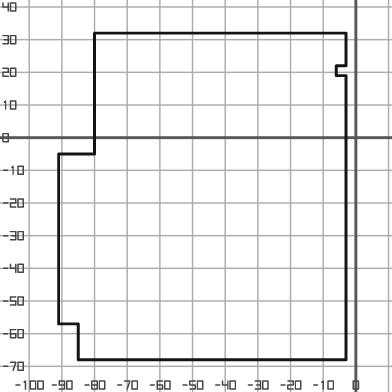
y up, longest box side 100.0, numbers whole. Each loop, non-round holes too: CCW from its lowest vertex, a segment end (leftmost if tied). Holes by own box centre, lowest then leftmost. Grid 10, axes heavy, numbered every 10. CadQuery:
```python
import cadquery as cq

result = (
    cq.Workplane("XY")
    .moveTo(-85.0, -68.0)
    .lineTo(-3.0, -68.0)
    .lineTo(-3.0, 19.0)
    .lineTo(-6.0, 19.0)
    .lineTo(-6.0, 22.0)
    .lineTo(-3.0, 22.0)
    .lineTo(-3.0, 32.0)
    .lineTo(-80.0, 32.0)
    .lineTo(-80.0, -5.0)
    .lineTo(-91.0, -5.0)
    .lineTo(-91.0, -57.0)
    .lineTo(-85.0, -57.0)
    .close()
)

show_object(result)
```